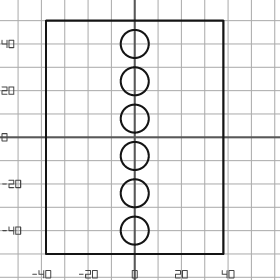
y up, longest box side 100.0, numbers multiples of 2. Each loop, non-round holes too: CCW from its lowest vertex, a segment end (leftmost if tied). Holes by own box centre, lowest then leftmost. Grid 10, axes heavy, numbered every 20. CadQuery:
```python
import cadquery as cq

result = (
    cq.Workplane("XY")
    .moveTo(-38.0, -50.0)
    .lineTo(38.0, -50.0)
    .lineTo(38.0, 50.0)
    .lineTo(-38.0, 50.0)
    .close()
    .moveTo(0.0, -40.0)
    .circle(6.0)
    .moveTo(0.0, -24.0)
    .circle(6.0)
    .moveTo(0.0, -8.0)
    .circle(6.0)
    .moveTo(0.0, 8.0)
    .circle(6.0)
    .moveTo(0.0, 24.0)
    .circle(6.0)
    .moveTo(0.0, 40.0)
    .circle(6.0)
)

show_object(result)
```